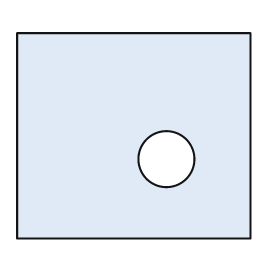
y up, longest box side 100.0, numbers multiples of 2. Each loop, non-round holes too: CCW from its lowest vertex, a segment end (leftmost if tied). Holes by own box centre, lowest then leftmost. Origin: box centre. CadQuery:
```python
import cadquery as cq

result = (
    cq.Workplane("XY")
    .moveTo(-50.0, -44.0)
    .lineTo(50.0, -44.0)
    .lineTo(50.0, 44.0)
    .lineTo(-50.0, 44.0)
    .close()
    .moveTo(14.0, -10.0)
    .circle(12.0)
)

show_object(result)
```